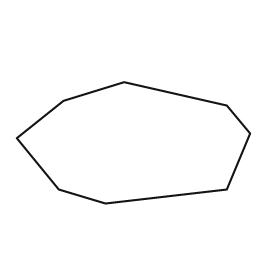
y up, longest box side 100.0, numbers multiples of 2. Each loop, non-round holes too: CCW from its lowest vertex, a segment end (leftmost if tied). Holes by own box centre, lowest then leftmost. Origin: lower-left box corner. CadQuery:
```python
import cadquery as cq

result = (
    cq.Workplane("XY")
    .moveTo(38.0, 0.0)
    .lineTo(90.0, 6.0)
    .lineTo(100.0, 30.0)
    .lineTo(90.0, 42.0)
    .lineTo(46.0, 52.0)
    .lineTo(20.0, 44.0)
    .lineTo(0.0, 28.0)
    .lineTo(18.0, 6.0)
    .close()
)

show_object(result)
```